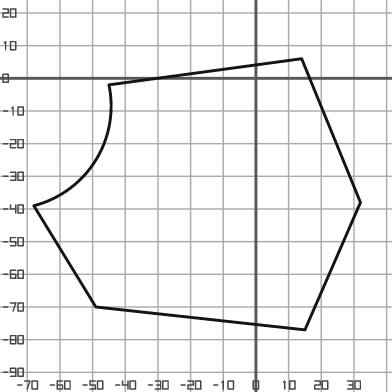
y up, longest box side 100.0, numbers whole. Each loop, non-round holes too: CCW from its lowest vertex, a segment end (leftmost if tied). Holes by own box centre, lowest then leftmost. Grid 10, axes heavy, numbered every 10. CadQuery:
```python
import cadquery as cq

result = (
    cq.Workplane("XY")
    .moveTo(15.0, -77.0)
    .lineTo(32.0, -38.0)
    .lineTo(14.0, 6.0)
    .lineTo(-45.0, -2.0)
    .threePointArc((-49.0, -25.0), (-68.0, -39.0))
    .lineTo(-49.0, -70.0)
    .close()
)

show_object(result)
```